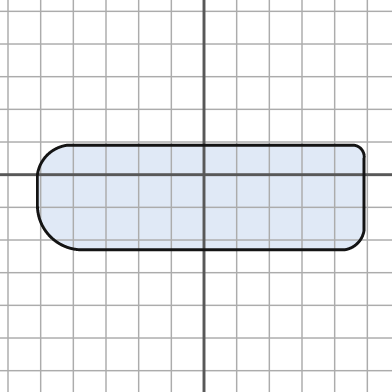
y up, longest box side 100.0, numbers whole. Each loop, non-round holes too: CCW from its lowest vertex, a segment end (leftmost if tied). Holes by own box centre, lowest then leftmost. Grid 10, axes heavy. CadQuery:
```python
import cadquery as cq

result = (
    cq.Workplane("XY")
    .moveTo(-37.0, -23.0)
    .lineTo(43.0, -23.0)
    .threePointArc((47.0, -21.0), (49.0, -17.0))
    .lineTo(49.0, 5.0)
    .threePointArc((48.0, 8.0), (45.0, 9.0))
    .lineTo(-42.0, 9.0)
    .threePointArc((-48.0, 6.0), (-51.0, 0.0))
    .lineTo(-51.0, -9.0)
    .threePointArc((-47.0, -19.0), (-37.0, -23.0))
    .close()
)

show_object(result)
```